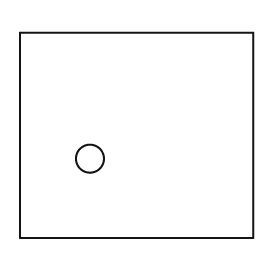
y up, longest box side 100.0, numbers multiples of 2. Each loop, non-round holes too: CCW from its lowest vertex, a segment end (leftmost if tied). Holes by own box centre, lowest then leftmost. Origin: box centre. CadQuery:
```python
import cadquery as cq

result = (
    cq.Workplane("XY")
    .moveTo(-50.0, -44.0)
    .lineTo(50.0, -44.0)
    .lineTo(50.0, 44.0)
    .lineTo(-50.0, 44.0)
    .close()
    .moveTo(-20.0, -10.0)
    .circle(6.0)
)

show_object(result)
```